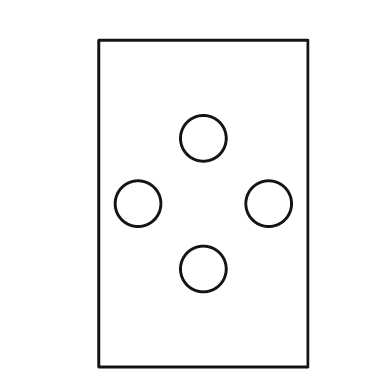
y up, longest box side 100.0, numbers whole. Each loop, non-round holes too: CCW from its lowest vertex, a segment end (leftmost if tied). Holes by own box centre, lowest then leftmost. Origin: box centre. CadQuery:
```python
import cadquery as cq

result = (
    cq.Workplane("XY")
    .moveTo(-32.0, -50.0)
    .lineTo(32.0, -50.0)
    .lineTo(32.0, 50.0)
    .lineTo(-32.0, 50.0)
    .close()
    .moveTo(0.0, -20.0)
    .circle(7.0)
    .moveTo(-20.0, 0.0)
    .circle(7.0)
    .moveTo(20.0, 0.0)
    .circle(7.0)
    .moveTo(0.0, 20.0)
    .circle(7.0)
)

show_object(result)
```